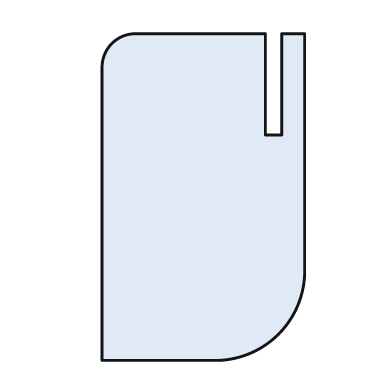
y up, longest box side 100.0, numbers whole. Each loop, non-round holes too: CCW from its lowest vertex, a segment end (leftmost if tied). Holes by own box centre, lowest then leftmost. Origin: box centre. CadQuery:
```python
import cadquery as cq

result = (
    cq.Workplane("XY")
    .moveTo(-31.0, -50.0)
    .lineTo(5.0, -50.0)
    .threePointArc((23.0, -42.0), (31.0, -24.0))
    .lineTo(31.0, 50.0)
    .lineTo(24.0, 50.0)
    .lineTo(24.0, 19.0)
    .lineTo(19.0, 19.0)
    .lineTo(19.0, 50.0)
    .lineTo(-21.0, 50.0)
    .threePointArc((-28.0, 47.0), (-31.0, 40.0))
    .close()
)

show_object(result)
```